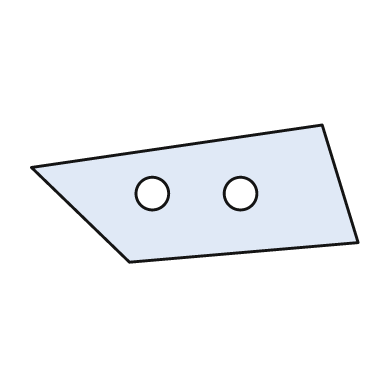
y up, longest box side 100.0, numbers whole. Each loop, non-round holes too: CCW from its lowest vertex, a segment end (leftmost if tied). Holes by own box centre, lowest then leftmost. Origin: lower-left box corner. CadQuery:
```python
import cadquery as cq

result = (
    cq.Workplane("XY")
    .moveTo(30.0, 0.0)
    .lineTo(100.0, 6.0)
    .lineTo(89.0, 42.0)
    .lineTo(0.0, 29.0)
    .close()
    .moveTo(37.0, 21.0)
    .circle(5.0)
    .moveTo(64.0, 21.0)
    .circle(5.0)
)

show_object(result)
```